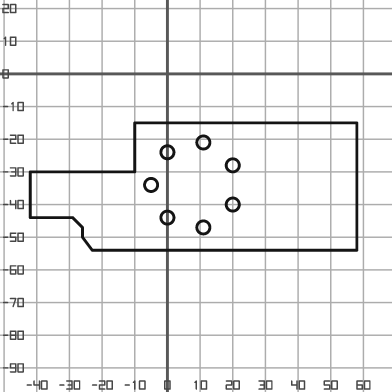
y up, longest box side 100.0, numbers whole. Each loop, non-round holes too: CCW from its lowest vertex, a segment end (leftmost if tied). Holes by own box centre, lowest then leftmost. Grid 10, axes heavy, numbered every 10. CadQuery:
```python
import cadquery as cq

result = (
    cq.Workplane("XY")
    .moveTo(-23.0, -54.0)
    .lineTo(58.0, -54.0)
    .lineTo(58.0, -15.0)
    .lineTo(-10.0, -15.0)
    .lineTo(-10.0, -30.0)
    .lineTo(-42.0, -30.0)
    .lineTo(-42.0, -44.0)
    .lineTo(-29.0, -44.0)
    .lineTo(-26.0, -47.0)
    .lineTo(-26.0, -50.0)
    .close()
    .moveTo(11.0, -47.0)
    .circle(2.0)
    .moveTo(0.0, -44.0)
    .circle(2.0)
    .moveTo(20.0, -40.0)
    .circle(2.0)
    .moveTo(-5.0, -34.0)
    .circle(2.0)
    .moveTo(20.0, -28.0)
    .circle(2.0)
    .moveTo(0.0, -24.0)
    .circle(2.0)
    .moveTo(11.0, -21.0)
    .circle(2.0)
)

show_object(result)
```